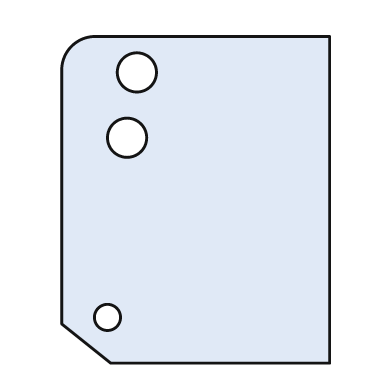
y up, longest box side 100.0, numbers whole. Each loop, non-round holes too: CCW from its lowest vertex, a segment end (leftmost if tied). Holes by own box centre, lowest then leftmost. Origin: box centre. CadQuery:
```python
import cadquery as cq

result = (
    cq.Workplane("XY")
    .moveTo(-26.0, -50.0)
    .lineTo(41.0, -50.0)
    .lineTo(41.0, 50.0)
    .lineTo(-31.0, 50.0)
    .threePointArc((-38.0, 47.0), (-41.0, 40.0))
    .lineTo(-41.0, -38.0)
    .close()
    .moveTo(-27.0, -36.0)
    .circle(4.0)
    .moveTo(-21.0, 19.0)
    .circle(6.0)
    .moveTo(-18.0, 39.0)
    .circle(6.0)
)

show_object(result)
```